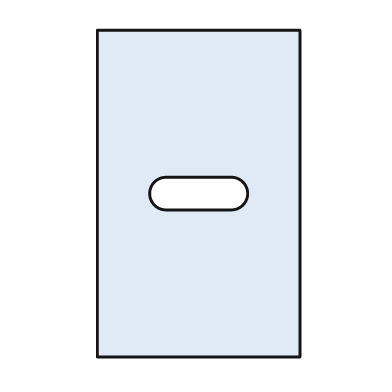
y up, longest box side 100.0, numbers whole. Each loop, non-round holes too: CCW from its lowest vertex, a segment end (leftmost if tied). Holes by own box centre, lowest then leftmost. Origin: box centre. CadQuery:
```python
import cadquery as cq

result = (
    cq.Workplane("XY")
    .moveTo(-31.0, -50.0)
    .lineTo(31.0, -50.0)
    .lineTo(31.0, 50.0)
    .lineTo(-31.0, 50.0)
    .close()
    .moveTo(-10.0, -5.0)
    .lineTo(10.0, -5.0)
    .threePointArc((15.0, 0.0), (10.0, 5.0))
    .lineTo(-10.0, 5.0)
    .threePointArc((-15.0, 0.0), (-10.0, -5.0))
    .close()
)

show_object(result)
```